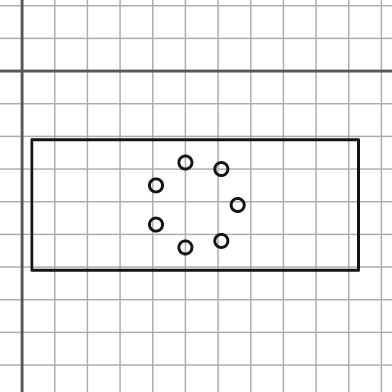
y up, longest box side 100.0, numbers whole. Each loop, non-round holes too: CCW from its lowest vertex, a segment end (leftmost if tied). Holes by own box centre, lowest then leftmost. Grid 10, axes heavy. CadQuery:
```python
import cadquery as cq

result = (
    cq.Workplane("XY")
    .moveTo(3.0, -61.0)
    .lineTo(103.0, -61.0)
    .lineTo(103.0, -21.0)
    .lineTo(3.0, -21.0)
    .close()
    .moveTo(50.0, -54.0)
    .circle(2.0)
    .moveTo(61.0, -52.0)
    .circle(2.0)
    .moveTo(41.0, -47.0)
    .circle(2.0)
    .moveTo(66.0, -41.0)
    .circle(2.0)
    .moveTo(41.0, -35.0)
    .circle(2.0)
    .moveTo(61.0, -30.0)
    .circle(2.0)
    .moveTo(50.0, -28.0)
    .circle(2.0)
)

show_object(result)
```